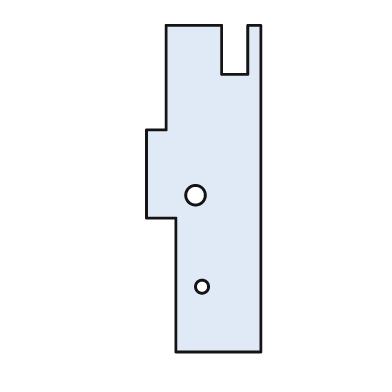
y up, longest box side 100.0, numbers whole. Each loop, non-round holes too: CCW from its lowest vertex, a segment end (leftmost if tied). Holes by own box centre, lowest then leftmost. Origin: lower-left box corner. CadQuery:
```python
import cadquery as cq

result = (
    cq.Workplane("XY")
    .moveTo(9.0, 0.0)
    .lineTo(35.0, 0.0)
    .lineTo(35.0, 100.0)
    .lineTo(31.0, 100.0)
    .lineTo(31.0, 85.0)
    .lineTo(23.0, 85.0)
    .lineTo(23.0, 100.0)
    .lineTo(6.0, 100.0)
    .lineTo(6.0, 68.0)
    .lineTo(0.0, 68.0)
    .lineTo(0.0, 41.0)
    .lineTo(9.0, 41.0)
    .close()
    .moveTo(17.0, 20.0)
    .circle(2.0)
    .moveTo(15.0, 48.0)
    .circle(3.0)
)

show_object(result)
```